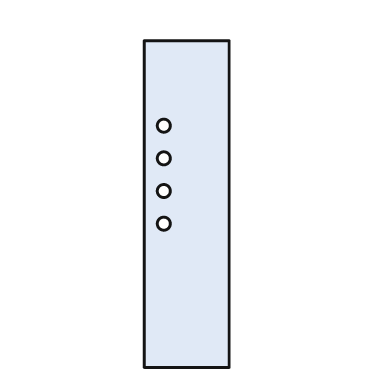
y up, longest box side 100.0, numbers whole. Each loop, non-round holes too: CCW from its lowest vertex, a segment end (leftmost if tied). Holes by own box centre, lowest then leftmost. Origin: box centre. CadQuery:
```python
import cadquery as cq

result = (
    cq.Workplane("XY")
    .moveTo(-13.0, -50.0)
    .lineTo(13.0, -50.0)
    .lineTo(13.0, 50.0)
    .lineTo(-13.0, 50.0)
    .close()
    .moveTo(-7.0, -6.0)
    .circle(2.0)
    .moveTo(-7.0, 4.0)
    .circle(2.0)
    .moveTo(-7.0, 14.0)
    .circle(2.0)
    .moveTo(-7.0, 24.0)
    .circle(2.0)
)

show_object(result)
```